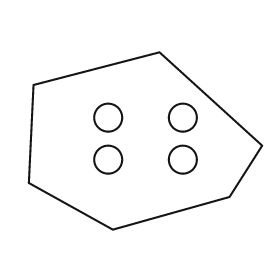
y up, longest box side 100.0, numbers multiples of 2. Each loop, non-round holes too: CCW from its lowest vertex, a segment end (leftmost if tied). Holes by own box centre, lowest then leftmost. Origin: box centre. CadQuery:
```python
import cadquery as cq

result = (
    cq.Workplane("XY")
    .moveTo(-14.0, -38.0)
    .lineTo(36.0, -24.0)
    .lineTo(50.0, -2.0)
    .lineTo(6.0, 38.0)
    .lineTo(-48.0, 24.0)
    .lineTo(-50.0, -18.0)
    .close()
    .moveTo(-16.0, -8.0)
    .circle(6.0)
    .moveTo(16.0, -8.0)
    .circle(6.0)
    .moveTo(-16.0, 10.0)
    .circle(6.0)
    .moveTo(16.0, 10.0)
    .circle(6.0)
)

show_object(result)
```